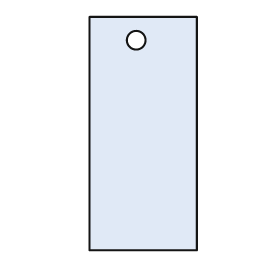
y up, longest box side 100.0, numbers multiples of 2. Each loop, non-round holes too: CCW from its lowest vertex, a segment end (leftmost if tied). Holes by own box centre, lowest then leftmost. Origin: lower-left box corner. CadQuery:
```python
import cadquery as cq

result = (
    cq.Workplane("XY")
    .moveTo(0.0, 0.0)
    .lineTo(46.0, 0.0)
    .lineTo(46.0, 100.0)
    .lineTo(0.0, 100.0)
    .close()
    .moveTo(20.0, 90.0)
    .circle(4.0)
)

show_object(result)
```